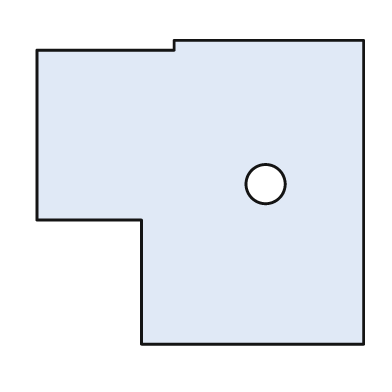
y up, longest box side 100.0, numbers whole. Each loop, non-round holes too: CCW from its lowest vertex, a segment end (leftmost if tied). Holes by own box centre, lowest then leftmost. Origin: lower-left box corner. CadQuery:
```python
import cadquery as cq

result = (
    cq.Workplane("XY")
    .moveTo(32.0, 0.0)
    .lineTo(100.0, 0.0)
    .lineTo(100.0, 93.0)
    .lineTo(42.0, 93.0)
    .lineTo(42.0, 90.0)
    .lineTo(0.0, 90.0)
    .lineTo(0.0, 38.0)
    .lineTo(32.0, 38.0)
    .close()
    .moveTo(70.0, 49.0)
    .circle(6.0)
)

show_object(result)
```